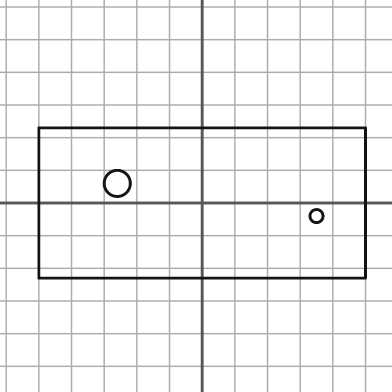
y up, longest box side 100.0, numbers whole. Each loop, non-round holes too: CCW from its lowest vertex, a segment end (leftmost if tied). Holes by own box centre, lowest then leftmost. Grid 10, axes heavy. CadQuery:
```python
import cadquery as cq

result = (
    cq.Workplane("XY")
    .moveTo(-50.0, -23.0)
    .lineTo(50.0, -23.0)
    .lineTo(50.0, 23.0)
    .lineTo(-50.0, 23.0)
    .close()
    .moveTo(35.0, -4.0)
    .circle(2.0)
    .moveTo(-26.0, 6.0)
    .circle(4.0)
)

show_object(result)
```